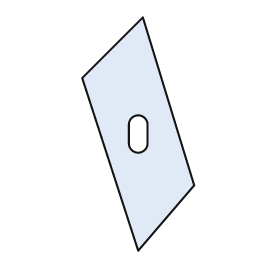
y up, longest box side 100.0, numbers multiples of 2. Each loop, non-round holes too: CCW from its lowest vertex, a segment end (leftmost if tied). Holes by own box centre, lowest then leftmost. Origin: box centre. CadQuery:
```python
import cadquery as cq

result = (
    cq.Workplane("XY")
    .moveTo(0.0, -50.0)
    .lineTo(24.0, -22.0)
    .lineTo(2.0, 50.0)
    .lineTo(-24.0, 24.0)
    .close()
    .moveTo(-4.0, -4.0)
    .threePointArc((0.0, -8.0), (4.0, -4.0))
    .lineTo(4.0, 4.0)
    .threePointArc((0.0, 8.0), (-4.0, 4.0))
    .close()
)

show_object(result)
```